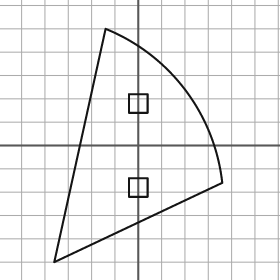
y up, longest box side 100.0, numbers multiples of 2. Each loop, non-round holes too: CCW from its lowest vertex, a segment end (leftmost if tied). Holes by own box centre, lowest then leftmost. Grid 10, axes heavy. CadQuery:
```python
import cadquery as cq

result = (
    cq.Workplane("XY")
    .moveTo(-36.0, -50.0)
    .lineTo(36.0, -16.0)
    .threePointArc((20.0, 24.0), (-14.0, 50.0))
    .close()
    .moveTo(-4.0, -22.0)
    .lineTo(4.0, -22.0)
    .lineTo(4.0, -14.0)
    .lineTo(-4.0, -14.0)
    .close()
    .moveTo(-4.0, 14.0)
    .lineTo(4.0, 14.0)
    .lineTo(4.0, 22.0)
    .lineTo(-4.0, 22.0)
    .close()
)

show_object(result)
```